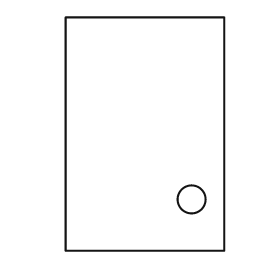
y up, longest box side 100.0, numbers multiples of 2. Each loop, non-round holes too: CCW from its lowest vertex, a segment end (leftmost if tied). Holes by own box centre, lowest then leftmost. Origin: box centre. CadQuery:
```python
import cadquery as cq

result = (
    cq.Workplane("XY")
    .moveTo(-34.0, -50.0)
    .lineTo(34.0, -50.0)
    .lineTo(34.0, 50.0)
    .lineTo(-34.0, 50.0)
    .close()
    .moveTo(20.0, -28.0)
    .circle(6.0)
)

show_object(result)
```